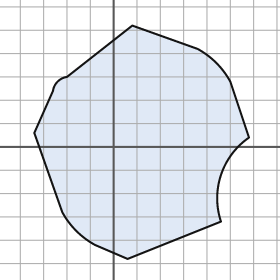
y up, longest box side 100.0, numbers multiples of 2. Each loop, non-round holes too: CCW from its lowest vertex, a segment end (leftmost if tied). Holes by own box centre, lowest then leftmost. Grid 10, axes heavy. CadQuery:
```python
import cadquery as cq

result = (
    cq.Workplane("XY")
    .moveTo(6.0, -48.0)
    .lineTo(46.0, -32.0)
    .threePointArc((46.0, -12.0), (58.0, 4.0))
    .lineTo(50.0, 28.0)
    .threePointArc((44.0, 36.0), (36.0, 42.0))
    .lineTo(8.0, 52.0)
    .lineTo(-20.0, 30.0)
    .threePointArc((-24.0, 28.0), (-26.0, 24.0))
    .lineTo(-34.0, 6.0)
    .lineTo(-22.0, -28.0)
    .threePointArc((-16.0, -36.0), (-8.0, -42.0))
    .close()
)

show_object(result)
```